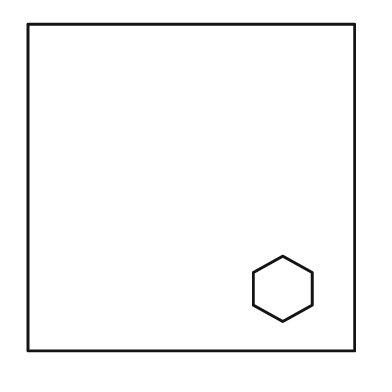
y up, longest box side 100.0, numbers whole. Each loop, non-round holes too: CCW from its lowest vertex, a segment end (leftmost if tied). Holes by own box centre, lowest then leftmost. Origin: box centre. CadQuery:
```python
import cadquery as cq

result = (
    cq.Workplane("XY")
    .moveTo(-50.0, -50.0)
    .lineTo(50.0, -50.0)
    .lineTo(50.0, 50.0)
    .lineTo(-50.0, 50.0)
    .close()
    .moveTo(28.0, -41.0)
    .lineTo(37.0, -36.0)
    .lineTo(37.0, -26.0)
    .lineTo(28.0, -21.0)
    .lineTo(19.0, -26.0)
    .lineTo(19.0, -36.0)
    .close()
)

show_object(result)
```